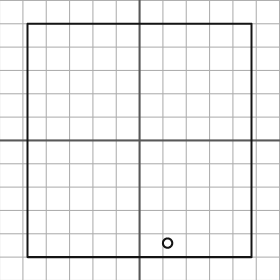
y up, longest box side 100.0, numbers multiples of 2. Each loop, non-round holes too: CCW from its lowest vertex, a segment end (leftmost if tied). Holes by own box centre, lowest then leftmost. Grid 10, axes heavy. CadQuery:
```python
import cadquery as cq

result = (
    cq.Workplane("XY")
    .moveTo(-48.0, -50.0)
    .lineTo(48.0, -50.0)
    .lineTo(48.0, 50.0)
    .lineTo(-48.0, 50.0)
    .close()
    .moveTo(12.0, -44.0)
    .circle(2.0)
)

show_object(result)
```